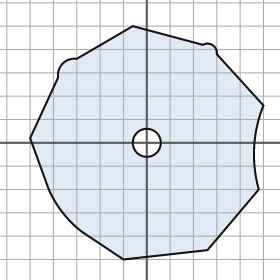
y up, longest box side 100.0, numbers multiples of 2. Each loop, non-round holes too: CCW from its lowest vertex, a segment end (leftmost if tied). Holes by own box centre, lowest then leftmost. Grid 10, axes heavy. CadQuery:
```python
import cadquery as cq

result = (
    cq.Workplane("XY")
    .moveTo(-10.0, -50.0)
    .lineTo(26.0, -46.0)
    .lineTo(48.0, -20.0)
    .threePointArc((46.0, -2.0), (50.0, 16.0))
    .lineTo(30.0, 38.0)
    .threePointArc((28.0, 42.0), (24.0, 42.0))
    .lineTo(-6.0, 50.0)
    .lineTo(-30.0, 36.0)
    .threePointArc((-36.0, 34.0), (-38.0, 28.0))
    .lineTo(-50.0, 2.0)
    .lineTo(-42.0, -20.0)
    .threePointArc((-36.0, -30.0), (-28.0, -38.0))
    .close()
    .moveTo(0.0, 0.0)
    .circle(6.0)
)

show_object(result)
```